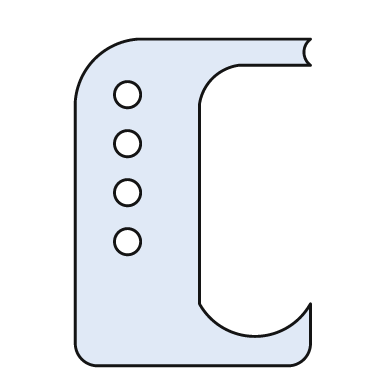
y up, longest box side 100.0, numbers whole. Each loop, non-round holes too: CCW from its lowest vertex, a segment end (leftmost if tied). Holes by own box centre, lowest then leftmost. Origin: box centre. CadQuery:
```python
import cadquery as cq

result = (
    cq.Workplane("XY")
    .moveTo(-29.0, -50.0)
    .lineTo(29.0, -50.0)
    .threePointArc((34.0, -48.0), (36.0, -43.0))
    .lineTo(36.0, -31.0)
    .threePointArc((19.0, -41.0), (2.0, -31.0))
    .lineTo(2.0, 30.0)
    .threePointArc((6.0, 38.0), (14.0, 42.0))
    .lineTo(36.0, 42.0)
    .threePointArc((34.0, 46.0), (36.0, 50.0))
    .lineTo(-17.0, 50.0)
    .threePointArc((-30.0, 44.0), (-36.0, 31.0))
    .lineTo(-36.0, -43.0)
    .threePointArc((-34.0, -48.0), (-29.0, -50.0))
    .close()
    .moveTo(-20.0, -12.0)
    .circle(4.0)
    .moveTo(-20.0, 3.0)
    .circle(4.0)
    .moveTo(-20.0, 18.0)
    .circle(4.0)
    .moveTo(-20.0, 33.0)
    .circle(4.0)
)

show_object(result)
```